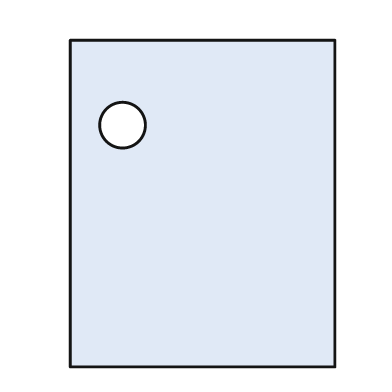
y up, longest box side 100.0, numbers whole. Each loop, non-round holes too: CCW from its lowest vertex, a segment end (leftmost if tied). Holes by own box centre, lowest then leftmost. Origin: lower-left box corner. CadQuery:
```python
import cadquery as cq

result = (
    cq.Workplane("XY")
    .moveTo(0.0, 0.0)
    .lineTo(81.0, 0.0)
    .lineTo(81.0, 100.0)
    .lineTo(0.0, 100.0)
    .close()
    .moveTo(16.0, 74.0)
    .circle(7.0)
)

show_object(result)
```